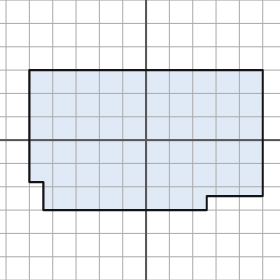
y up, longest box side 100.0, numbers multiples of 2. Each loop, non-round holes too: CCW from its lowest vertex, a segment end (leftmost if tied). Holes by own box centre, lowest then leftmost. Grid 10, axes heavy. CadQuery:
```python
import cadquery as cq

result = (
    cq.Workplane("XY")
    .moveTo(-44.0, -30.0)
    .lineTo(26.0, -30.0)
    .lineTo(26.0, -24.0)
    .lineTo(50.0, -24.0)
    .lineTo(50.0, 30.0)
    .lineTo(-50.0, 30.0)
    .lineTo(-50.0, -18.0)
    .lineTo(-44.0, -18.0)
    .close()
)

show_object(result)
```